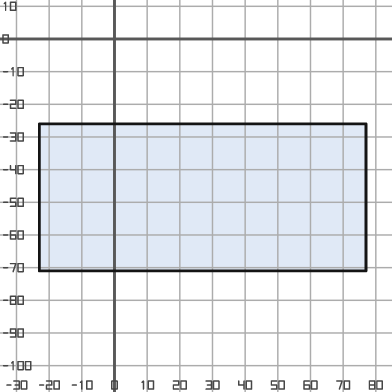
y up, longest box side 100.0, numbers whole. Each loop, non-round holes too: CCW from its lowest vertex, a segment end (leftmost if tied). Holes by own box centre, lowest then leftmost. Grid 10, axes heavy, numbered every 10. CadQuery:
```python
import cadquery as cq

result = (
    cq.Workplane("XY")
    .moveTo(-23.0, -71.0)
    .lineTo(77.0, -71.0)
    .lineTo(77.0, -26.0)
    .lineTo(-23.0, -26.0)
    .close()
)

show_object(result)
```